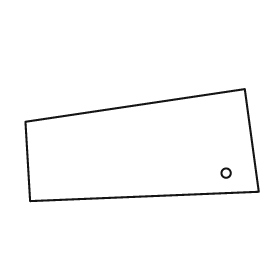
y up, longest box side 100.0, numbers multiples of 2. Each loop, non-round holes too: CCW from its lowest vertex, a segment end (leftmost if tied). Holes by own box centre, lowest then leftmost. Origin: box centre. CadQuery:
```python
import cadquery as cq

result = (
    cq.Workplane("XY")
    .moveTo(-48.0, -24.0)
    .lineTo(50.0, -20.0)
    .lineTo(44.0, 24.0)
    .lineTo(-50.0, 10.0)
    .close()
    .moveTo(36.0, -12.0)
    .circle(2.0)
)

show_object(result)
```